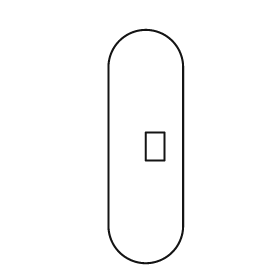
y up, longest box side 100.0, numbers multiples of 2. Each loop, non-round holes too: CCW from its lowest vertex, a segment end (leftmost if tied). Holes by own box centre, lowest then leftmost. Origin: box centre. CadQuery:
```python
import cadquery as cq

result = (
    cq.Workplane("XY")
    .moveTo(-16.0, -34.0)
    .threePointArc((0.0, -50.0), (16.0, -34.0))
    .lineTo(16.0, 34.0)
    .threePointArc((0.0, 50.0), (-16.0, 34.0))
    .close()
    .moveTo(0.0, -6.0)
    .lineTo(8.0, -6.0)
    .lineTo(8.0, 6.0)
    .lineTo(0.0, 6.0)
    .close()
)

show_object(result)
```